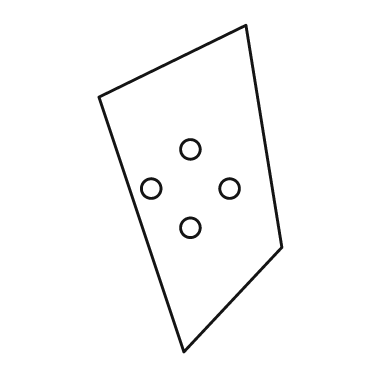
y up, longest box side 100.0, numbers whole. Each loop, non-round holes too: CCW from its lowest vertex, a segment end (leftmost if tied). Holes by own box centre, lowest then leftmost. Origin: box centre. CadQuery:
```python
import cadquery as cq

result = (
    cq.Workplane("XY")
    .moveTo(-2.0, -50.0)
    .lineTo(28.0, -18.0)
    .lineTo(17.0, 50.0)
    .lineTo(-28.0, 28.0)
    .close()
    .moveTo(0.0, -12.0)
    .circle(3.0)
    .moveTo(-12.0, 0.0)
    .circle(3.0)
    .moveTo(12.0, 0.0)
    .circle(3.0)
    .moveTo(0.0, 12.0)
    .circle(3.0)
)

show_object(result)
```